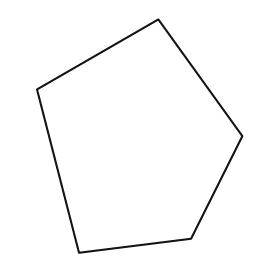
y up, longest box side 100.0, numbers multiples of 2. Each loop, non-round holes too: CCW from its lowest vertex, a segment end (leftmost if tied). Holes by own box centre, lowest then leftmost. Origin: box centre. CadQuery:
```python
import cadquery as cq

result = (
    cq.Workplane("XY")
    .moveTo(-26.0, -50.0)
    .lineTo(22.0, -44.0)
    .lineTo(44.0, 0.0)
    .lineTo(8.0, 50.0)
    .lineTo(-44.0, 20.0)
    .close()
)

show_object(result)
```